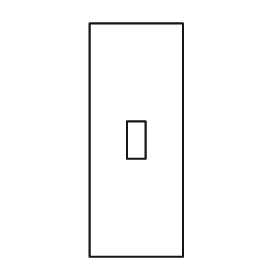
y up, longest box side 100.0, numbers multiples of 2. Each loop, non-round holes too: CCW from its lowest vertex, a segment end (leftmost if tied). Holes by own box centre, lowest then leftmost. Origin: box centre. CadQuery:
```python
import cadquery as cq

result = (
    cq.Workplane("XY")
    .moveTo(-20.0, -50.0)
    .lineTo(20.0, -50.0)
    .lineTo(20.0, 50.0)
    .lineTo(-20.0, 50.0)
    .close()
    .moveTo(-4.0, -8.0)
    .lineTo(4.0, -8.0)
    .lineTo(4.0, 8.0)
    .lineTo(-4.0, 8.0)
    .close()
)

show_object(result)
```